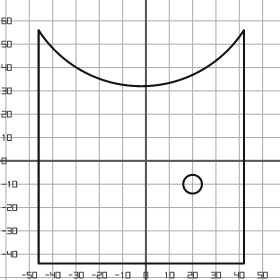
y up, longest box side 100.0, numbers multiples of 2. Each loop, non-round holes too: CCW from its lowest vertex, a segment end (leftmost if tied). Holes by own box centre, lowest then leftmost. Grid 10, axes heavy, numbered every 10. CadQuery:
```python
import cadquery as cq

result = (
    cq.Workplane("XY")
    .moveTo(-46.0, -44.0)
    .lineTo(42.0, -44.0)
    .lineTo(42.0, 56.0)
    .threePointArc((-2.0, 32.0), (-46.0, 56.0))
    .close()
    .moveTo(20.0, -10.0)
    .circle(4.0)
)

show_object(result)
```